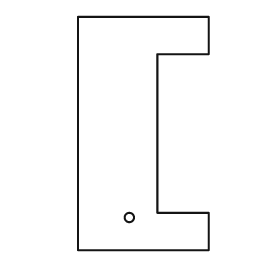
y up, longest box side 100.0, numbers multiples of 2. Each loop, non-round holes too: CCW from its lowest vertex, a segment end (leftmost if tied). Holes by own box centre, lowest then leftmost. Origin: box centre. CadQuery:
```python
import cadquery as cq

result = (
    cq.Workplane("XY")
    .moveTo(-28.0, -50.0)
    .lineTo(28.0, -50.0)
    .lineTo(28.0, -34.0)
    .lineTo(6.0, -34.0)
    .lineTo(6.0, 34.0)
    .lineTo(28.0, 34.0)
    .lineTo(28.0, 50.0)
    .lineTo(-28.0, 50.0)
    .close()
    .moveTo(-6.0, -36.0)
    .circle(2.0)
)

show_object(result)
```